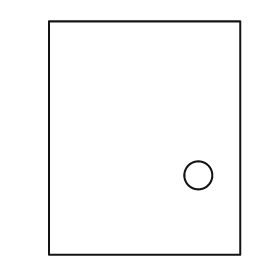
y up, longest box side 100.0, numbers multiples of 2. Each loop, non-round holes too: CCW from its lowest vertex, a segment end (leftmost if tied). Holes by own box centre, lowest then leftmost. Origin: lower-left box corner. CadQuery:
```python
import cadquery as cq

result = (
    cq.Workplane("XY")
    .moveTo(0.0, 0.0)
    .lineTo(82.0, 0.0)
    .lineTo(82.0, 100.0)
    .lineTo(0.0, 100.0)
    .close()
    .moveTo(64.0, 34.0)
    .circle(6.0)
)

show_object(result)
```